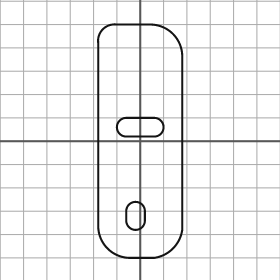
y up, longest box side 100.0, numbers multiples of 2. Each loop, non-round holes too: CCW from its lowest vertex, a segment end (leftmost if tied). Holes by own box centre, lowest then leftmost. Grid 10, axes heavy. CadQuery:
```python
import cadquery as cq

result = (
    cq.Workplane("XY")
    .moveTo(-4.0, -50.0)
    .lineTo(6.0, -50.0)
    .threePointArc((14.0, -46.0), (18.0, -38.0))
    .lineTo(18.0, 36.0)
    .threePointArc((14.0, 46.0), (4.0, 50.0))
    .lineTo(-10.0, 50.0)
    .threePointArc((-16.0, 48.0), (-18.0, 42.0))
    .lineTo(-18.0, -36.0)
    .threePointArc((-14.0, -46.0), (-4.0, -50.0))
    .close()
    .moveTo(-6.0, -34.0)
    .threePointArc((-2.0, -38.0), (2.0, -34.0))
    .lineTo(2.0, -30.0)
    .threePointArc((-2.0, -26.0), (-6.0, -30.0))
    .close()
    .moveTo(-6.0, 2.0)
    .lineTo(6.0, 2.0)
    .threePointArc((10.0, 6.0), (6.0, 10.0))
    .lineTo(-6.0, 10.0)
    .threePointArc((-10.0, 6.0), (-6.0, 2.0))
    .close()
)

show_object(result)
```